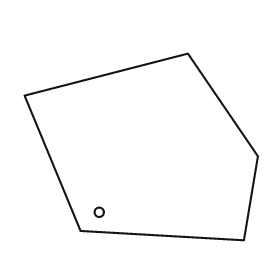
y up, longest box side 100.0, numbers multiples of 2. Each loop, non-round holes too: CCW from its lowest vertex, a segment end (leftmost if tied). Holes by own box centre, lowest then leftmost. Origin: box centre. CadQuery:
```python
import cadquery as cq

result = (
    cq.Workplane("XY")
    .moveTo(44.0, -40.0)
    .lineTo(50.0, -4.0)
    .lineTo(20.0, 40.0)
    .lineTo(-50.0, 22.0)
    .lineTo(-26.0, -36.0)
    .close()
    .moveTo(-18.0, -28.0)
    .circle(2.0)
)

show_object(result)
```